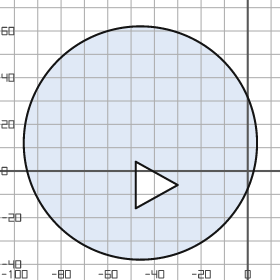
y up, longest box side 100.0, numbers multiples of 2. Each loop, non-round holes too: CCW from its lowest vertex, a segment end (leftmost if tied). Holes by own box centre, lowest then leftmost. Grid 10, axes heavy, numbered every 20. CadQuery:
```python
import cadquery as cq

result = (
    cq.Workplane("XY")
    .moveTo(-46.0, 12.0)
    .circle(50.0)
    .moveTo(-48.0, -16.0)
    .lineTo(-30.0, -6.0)
    .lineTo(-48.0, 4.0)
    .close()
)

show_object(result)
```